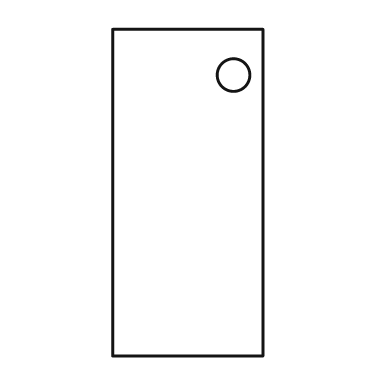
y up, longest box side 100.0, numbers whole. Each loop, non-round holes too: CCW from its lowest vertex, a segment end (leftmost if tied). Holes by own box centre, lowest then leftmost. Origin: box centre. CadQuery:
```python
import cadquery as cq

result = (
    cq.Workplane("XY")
    .moveTo(-23.0, -50.0)
    .lineTo(23.0, -50.0)
    .lineTo(23.0, 50.0)
    .lineTo(-23.0, 50.0)
    .close()
    .moveTo(14.0, 36.0)
    .circle(5.0)
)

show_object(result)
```